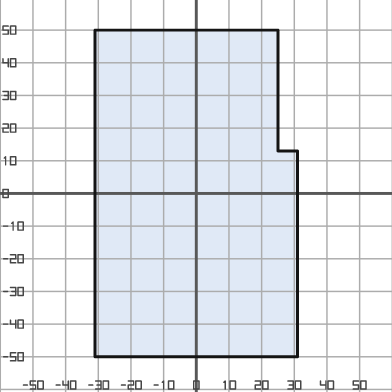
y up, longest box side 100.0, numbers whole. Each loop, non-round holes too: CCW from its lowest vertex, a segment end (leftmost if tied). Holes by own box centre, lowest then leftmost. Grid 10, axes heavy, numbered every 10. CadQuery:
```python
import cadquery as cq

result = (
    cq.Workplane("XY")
    .moveTo(-31.0, -50.0)
    .lineTo(31.0, -50.0)
    .lineTo(31.0, 13.0)
    .lineTo(25.0, 13.0)
    .lineTo(25.0, 50.0)
    .lineTo(-31.0, 50.0)
    .close()
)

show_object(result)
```